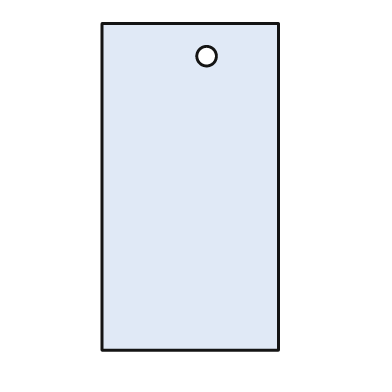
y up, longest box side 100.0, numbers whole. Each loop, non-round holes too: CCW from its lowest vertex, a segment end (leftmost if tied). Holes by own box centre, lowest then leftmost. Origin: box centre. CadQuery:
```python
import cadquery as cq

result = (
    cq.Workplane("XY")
    .moveTo(-27.0, -50.0)
    .lineTo(27.0, -50.0)
    .lineTo(27.0, 50.0)
    .lineTo(-27.0, 50.0)
    .close()
    .moveTo(5.0, 40.0)
    .circle(3.0)
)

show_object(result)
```